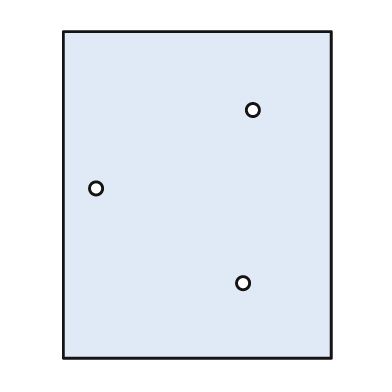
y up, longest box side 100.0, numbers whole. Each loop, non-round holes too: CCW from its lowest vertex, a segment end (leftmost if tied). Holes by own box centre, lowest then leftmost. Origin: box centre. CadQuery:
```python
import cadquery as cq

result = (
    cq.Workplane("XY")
    .moveTo(-41.0, -50.0)
    .lineTo(41.0, -50.0)
    .lineTo(41.0, 50.0)
    .lineTo(-41.0, 50.0)
    .close()
    .moveTo(14.0, -27.0)
    .circle(2.0)
    .moveTo(-31.0, 2.0)
    .circle(2.0)
    .moveTo(17.0, 26.0)
    .circle(2.0)
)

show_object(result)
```